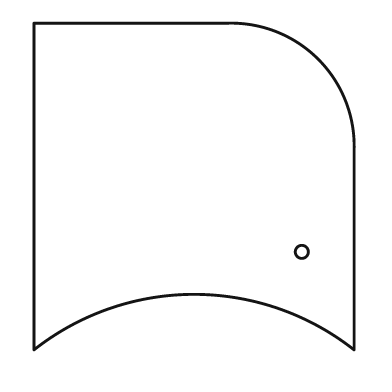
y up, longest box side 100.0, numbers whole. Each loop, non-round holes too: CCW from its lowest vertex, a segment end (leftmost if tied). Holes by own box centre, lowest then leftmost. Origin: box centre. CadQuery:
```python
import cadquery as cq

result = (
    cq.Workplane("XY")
    .moveTo(-49.0, -50.0)
    .threePointArc((0.0, -33.0), (49.0, -50.0))
    .lineTo(49.0, 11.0)
    .threePointArc((38.0, 39.0), (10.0, 50.0))
    .lineTo(-49.0, 50.0)
    .close()
    .moveTo(33.0, -20.0)
    .circle(2.0)
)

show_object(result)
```